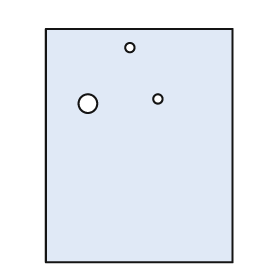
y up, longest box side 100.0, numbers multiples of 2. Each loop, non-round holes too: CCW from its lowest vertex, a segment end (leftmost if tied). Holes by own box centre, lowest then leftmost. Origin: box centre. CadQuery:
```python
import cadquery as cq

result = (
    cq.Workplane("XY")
    .moveTo(-40.0, -50.0)
    .lineTo(40.0, -50.0)
    .lineTo(40.0, 50.0)
    .lineTo(-40.0, 50.0)
    .close()
    .moveTo(-22.0, 18.0)
    .circle(4.0)
    .moveTo(8.0, 20.0)
    .circle(2.0)
    .moveTo(-4.0, 42.0)
    .circle(2.0)
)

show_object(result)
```